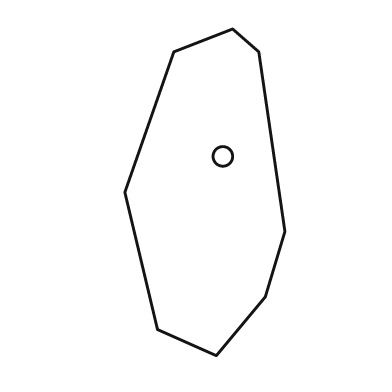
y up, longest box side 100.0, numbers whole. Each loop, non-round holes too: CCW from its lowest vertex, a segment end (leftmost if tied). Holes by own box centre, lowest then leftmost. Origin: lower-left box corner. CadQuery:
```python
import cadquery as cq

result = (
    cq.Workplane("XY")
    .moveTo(28.0, 0.0)
    .lineTo(43.0, 18.0)
    .lineTo(49.0, 38.0)
    .lineTo(41.0, 93.0)
    .lineTo(33.0, 100.0)
    .lineTo(15.0, 93.0)
    .lineTo(0.0, 50.0)
    .lineTo(10.0, 8.0)
    .close()
    .moveTo(30.0, 61.0)
    .circle(3.0)
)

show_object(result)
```